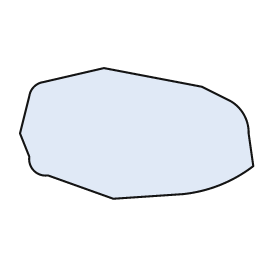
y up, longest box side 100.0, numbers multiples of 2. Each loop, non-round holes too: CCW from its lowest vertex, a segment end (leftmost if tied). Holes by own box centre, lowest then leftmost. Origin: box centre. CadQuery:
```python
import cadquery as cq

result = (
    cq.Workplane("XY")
    .moveTo(-10.0, -28.0)
    .lineTo(20.0, -26.0)
    .threePointArc((36.0, -22.0), (50.0, -14.0))
    .lineTo(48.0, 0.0)
    .threePointArc((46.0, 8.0), (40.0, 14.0))
    .lineTo(28.0, 20.0)
    .lineTo(-14.0, 28.0)
    .lineTo(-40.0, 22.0)
    .threePointArc((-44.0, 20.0), (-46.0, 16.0))
    .lineTo(-50.0, 0.0)
    .lineTo(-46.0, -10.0)
    .threePointArc((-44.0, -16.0), (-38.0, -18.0))
    .close()
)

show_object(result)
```